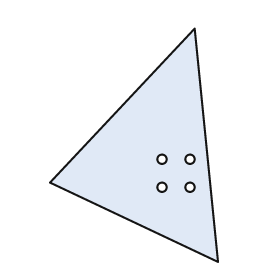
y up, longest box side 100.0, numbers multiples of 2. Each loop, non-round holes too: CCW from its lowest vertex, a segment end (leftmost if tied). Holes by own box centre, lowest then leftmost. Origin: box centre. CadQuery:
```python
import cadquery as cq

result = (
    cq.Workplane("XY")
    .moveTo(36.0, -50.0)
    .lineTo(26.0, 50.0)
    .lineTo(-36.0, -16.0)
    .close()
    .moveTo(12.0, -18.0)
    .circle(2.0)
    .moveTo(24.0, -18.0)
    .circle(2.0)
    .moveTo(12.0, -6.0)
    .circle(2.0)
    .moveTo(24.0, -6.0)
    .circle(2.0)
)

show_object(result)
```